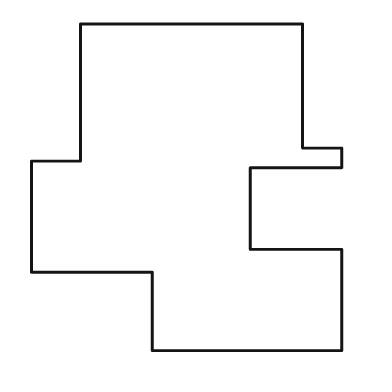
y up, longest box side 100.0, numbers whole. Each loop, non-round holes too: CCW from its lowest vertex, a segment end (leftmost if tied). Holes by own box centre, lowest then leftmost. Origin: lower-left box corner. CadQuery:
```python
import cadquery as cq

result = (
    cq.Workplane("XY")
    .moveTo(37.0, 0.0)
    .lineTo(95.0, 0.0)
    .lineTo(95.0, 31.0)
    .lineTo(67.0, 31.0)
    .lineTo(67.0, 56.0)
    .lineTo(95.0, 56.0)
    .lineTo(95.0, 62.0)
    .lineTo(83.0, 62.0)
    .lineTo(83.0, 100.0)
    .lineTo(15.0, 100.0)
    .lineTo(15.0, 58.0)
    .lineTo(0.0, 58.0)
    .lineTo(0.0, 24.0)
    .lineTo(37.0, 24.0)
    .close()
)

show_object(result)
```